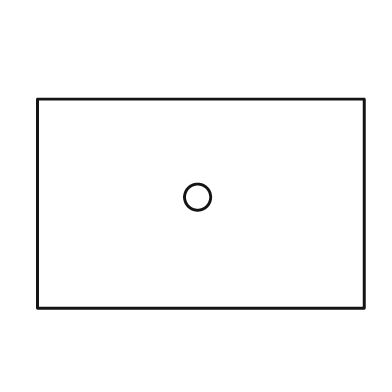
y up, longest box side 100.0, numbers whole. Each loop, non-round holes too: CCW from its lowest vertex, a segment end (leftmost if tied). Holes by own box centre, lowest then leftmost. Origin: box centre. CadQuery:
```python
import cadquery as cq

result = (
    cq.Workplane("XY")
    .moveTo(-50.0, -32.0)
    .lineTo(50.0, -32.0)
    .lineTo(50.0, 32.0)
    .lineTo(-50.0, 32.0)
    .close()
    .moveTo(-1.0, 2.0)
    .circle(4.0)
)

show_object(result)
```